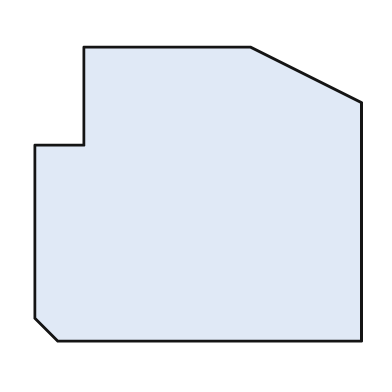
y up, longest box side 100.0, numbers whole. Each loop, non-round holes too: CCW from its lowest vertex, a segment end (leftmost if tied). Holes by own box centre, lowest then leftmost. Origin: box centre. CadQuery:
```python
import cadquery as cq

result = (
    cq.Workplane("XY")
    .moveTo(-43.0, -45.0)
    .lineTo(50.0, -45.0)
    .lineTo(50.0, 28.0)
    .lineTo(16.0, 45.0)
    .lineTo(-35.0, 45.0)
    .lineTo(-35.0, 15.0)
    .lineTo(-50.0, 15.0)
    .lineTo(-50.0, -38.0)
    .close()
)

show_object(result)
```